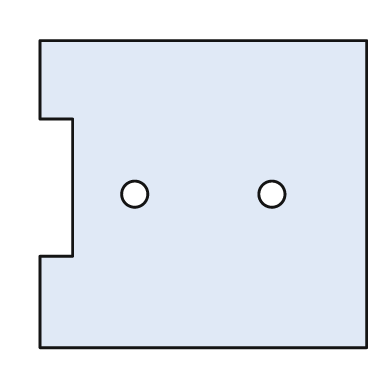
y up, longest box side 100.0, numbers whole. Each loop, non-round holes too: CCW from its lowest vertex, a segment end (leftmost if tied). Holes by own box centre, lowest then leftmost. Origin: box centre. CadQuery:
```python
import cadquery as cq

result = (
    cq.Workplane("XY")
    .moveTo(-50.0, -47.0)
    .lineTo(50.0, -47.0)
    .lineTo(50.0, 47.0)
    .lineTo(-50.0, 47.0)
    .lineTo(-50.0, 23.0)
    .lineTo(-40.0, 23.0)
    .lineTo(-40.0, -19.0)
    .lineTo(-50.0, -19.0)
    .close()
    .moveTo(-21.0, 0.0)
    .circle(4.0)
    .moveTo(21.0, 0.0)
    .circle(4.0)
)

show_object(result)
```